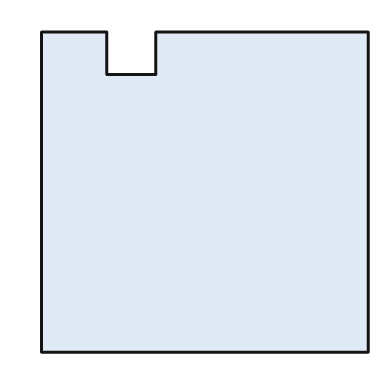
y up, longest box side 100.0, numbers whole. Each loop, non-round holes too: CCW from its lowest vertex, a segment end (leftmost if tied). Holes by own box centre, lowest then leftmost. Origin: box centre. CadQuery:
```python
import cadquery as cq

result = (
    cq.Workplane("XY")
    .moveTo(-50.0, -49.0)
    .lineTo(50.0, -49.0)
    .lineTo(50.0, 49.0)
    .lineTo(-15.0, 49.0)
    .lineTo(-15.0, 36.0)
    .lineTo(-30.0, 36.0)
    .lineTo(-30.0, 49.0)
    .lineTo(-50.0, 49.0)
    .close()
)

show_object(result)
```